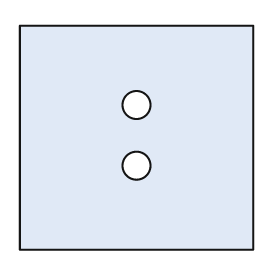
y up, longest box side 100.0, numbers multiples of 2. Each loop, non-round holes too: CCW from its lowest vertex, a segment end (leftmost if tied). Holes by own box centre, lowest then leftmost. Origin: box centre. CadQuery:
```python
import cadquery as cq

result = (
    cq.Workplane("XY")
    .moveTo(-50.0, -48.0)
    .lineTo(50.0, -48.0)
    .lineTo(50.0, 48.0)
    .lineTo(-50.0, 48.0)
    .close()
    .moveTo(0.0, -12.0)
    .circle(6.0)
    .moveTo(0.0, 14.0)
    .circle(6.0)
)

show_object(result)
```